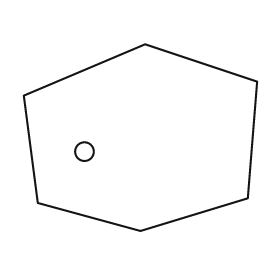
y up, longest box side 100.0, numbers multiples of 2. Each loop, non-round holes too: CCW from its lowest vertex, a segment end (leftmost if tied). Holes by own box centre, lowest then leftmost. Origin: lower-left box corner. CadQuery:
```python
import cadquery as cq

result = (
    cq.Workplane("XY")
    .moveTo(50.0, 0.0)
    .lineTo(96.0, 14.0)
    .lineTo(100.0, 64.0)
    .lineTo(52.0, 80.0)
    .lineTo(0.0, 58.0)
    .lineTo(6.0, 12.0)
    .close()
    .moveTo(26.0, 34.0)
    .circle(4.0)
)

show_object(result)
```